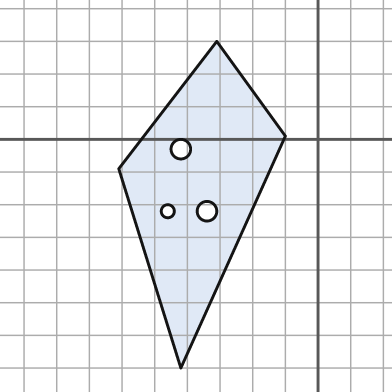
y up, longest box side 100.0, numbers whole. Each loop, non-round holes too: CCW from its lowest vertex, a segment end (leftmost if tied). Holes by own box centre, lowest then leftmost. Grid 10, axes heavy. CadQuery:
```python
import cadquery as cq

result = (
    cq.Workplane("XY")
    .moveTo(-42.0, -70.0)
    .lineTo(-10.0, 1.0)
    .lineTo(-31.0, 30.0)
    .lineTo(-61.0, -9.0)
    .close()
    .moveTo(-46.0, -22.0)
    .circle(2.0)
    .moveTo(-34.0, -22.0)
    .circle(3.0)
    .moveTo(-42.0, -3.0)
    .circle(3.0)
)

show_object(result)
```